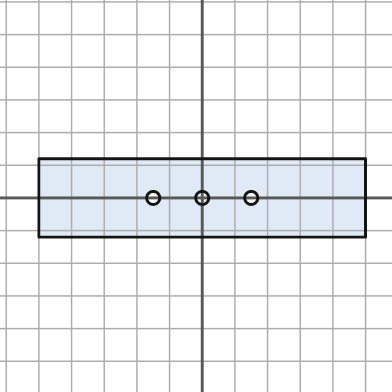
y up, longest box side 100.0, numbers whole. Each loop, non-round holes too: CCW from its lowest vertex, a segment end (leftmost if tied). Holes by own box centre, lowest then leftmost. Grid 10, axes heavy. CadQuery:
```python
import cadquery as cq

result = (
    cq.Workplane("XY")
    .moveTo(-50.0, -12.0)
    .lineTo(50.0, -12.0)
    .lineTo(50.0, 12.0)
    .lineTo(-50.0, 12.0)
    .close()
    .moveTo(-15.0, 0.0)
    .circle(2.0)
    .moveTo(0.0, 0.0)
    .circle(2.0)
    .moveTo(15.0, 0.0)
    .circle(2.0)
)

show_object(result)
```